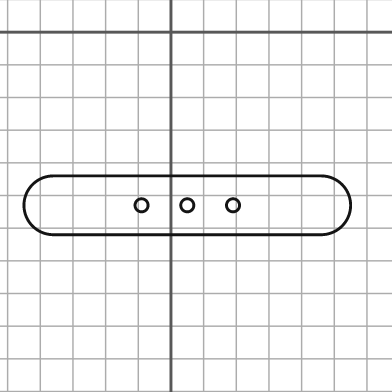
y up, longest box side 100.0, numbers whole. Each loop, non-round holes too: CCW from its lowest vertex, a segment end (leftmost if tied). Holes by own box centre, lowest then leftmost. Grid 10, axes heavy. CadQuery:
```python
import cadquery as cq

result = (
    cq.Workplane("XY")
    .moveTo(-36.0, -62.0)
    .lineTo(46.0, -62.0)
    .threePointArc((55.0, -53.0), (46.0, -44.0))
    .lineTo(-36.0, -44.0)
    .threePointArc((-45.0, -53.0), (-36.0, -62.0))
    .close()
    .moveTo(-9.0, -53.0)
    .circle(2.0)
    .moveTo(5.0, -53.0)
    .circle(2.0)
    .moveTo(19.0, -53.0)
    .circle(2.0)
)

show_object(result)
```